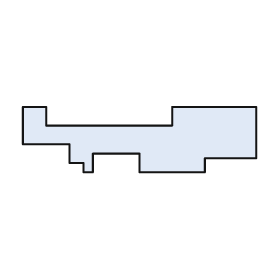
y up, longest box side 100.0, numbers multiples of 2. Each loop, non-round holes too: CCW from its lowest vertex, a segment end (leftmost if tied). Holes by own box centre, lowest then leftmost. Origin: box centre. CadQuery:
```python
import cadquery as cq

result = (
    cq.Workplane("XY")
    .moveTo(-24.0, -14.0)
    .lineTo(-20.0, -14.0)
    .lineTo(-20.0, -6.0)
    .lineTo(0.0, -6.0)
    .lineTo(0.0, -14.0)
    .lineTo(28.0, -14.0)
    .lineTo(28.0, -8.0)
    .lineTo(50.0, -8.0)
    .lineTo(50.0, 14.0)
    .lineTo(14.0, 14.0)
    .lineTo(14.0, 6.0)
    .lineTo(-40.0, 6.0)
    .lineTo(-40.0, 14.0)
    .lineTo(-50.0, 14.0)
    .lineTo(-50.0, -2.0)
    .lineTo(-30.0, -2.0)
    .lineTo(-30.0, -10.0)
    .lineTo(-24.0, -10.0)
    .close()
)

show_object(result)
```